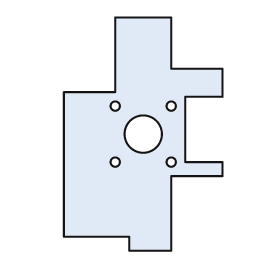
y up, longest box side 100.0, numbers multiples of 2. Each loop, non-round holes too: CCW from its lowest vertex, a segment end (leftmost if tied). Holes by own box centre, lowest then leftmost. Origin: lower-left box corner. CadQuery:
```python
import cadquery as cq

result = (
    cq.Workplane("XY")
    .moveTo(28.0, 0.0)
    .lineTo(46.0, 0.0)
    .lineTo(46.0, 32.0)
    .lineTo(68.0, 32.0)
    .lineTo(68.0, 38.0)
    .lineTo(52.0, 38.0)
    .lineTo(52.0, 66.0)
    .lineTo(68.0, 66.0)
    .lineTo(68.0, 78.0)
    .lineTo(46.0, 78.0)
    .lineTo(46.0, 100.0)
    .lineTo(22.0, 100.0)
    .lineTo(22.0, 68.0)
    .lineTo(0.0, 68.0)
    .lineTo(0.0, 6.0)
    .lineTo(28.0, 6.0)
    .close()
    .moveTo(22.0, 38.0)
    .circle(2.0)
    .moveTo(46.0, 38.0)
    .circle(2.0)
    .moveTo(34.0, 50.0)
    .circle(8.0)
    .moveTo(22.0, 62.0)
    .circle(2.0)
    .moveTo(46.0, 62.0)
    .circle(2.0)
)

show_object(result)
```